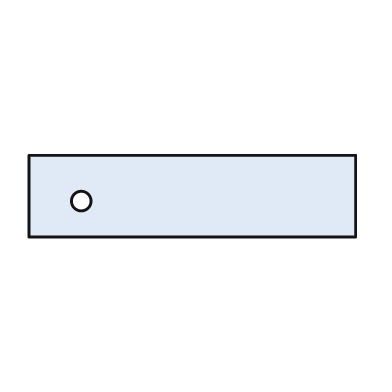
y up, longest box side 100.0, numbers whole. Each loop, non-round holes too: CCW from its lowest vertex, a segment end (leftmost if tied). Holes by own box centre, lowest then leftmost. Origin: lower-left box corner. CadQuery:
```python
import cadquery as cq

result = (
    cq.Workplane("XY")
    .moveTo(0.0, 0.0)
    .lineTo(100.0, 0.0)
    .lineTo(100.0, 25.0)
    .lineTo(0.0, 25.0)
    .close()
    .moveTo(16.0, 11.0)
    .circle(3.0)
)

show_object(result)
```